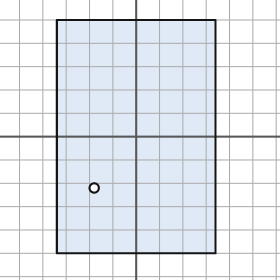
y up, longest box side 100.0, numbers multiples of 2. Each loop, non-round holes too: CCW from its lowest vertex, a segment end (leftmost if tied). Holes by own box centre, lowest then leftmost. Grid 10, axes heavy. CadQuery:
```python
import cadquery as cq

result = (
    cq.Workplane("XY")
    .moveTo(-34.0, -50.0)
    .lineTo(34.0, -50.0)
    .lineTo(34.0, 50.0)
    .lineTo(-34.0, 50.0)
    .close()
    .moveTo(-18.0, -22.0)
    .circle(2.0)
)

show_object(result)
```